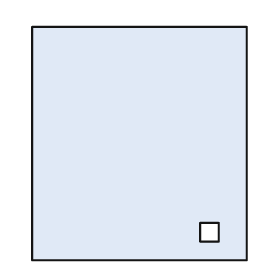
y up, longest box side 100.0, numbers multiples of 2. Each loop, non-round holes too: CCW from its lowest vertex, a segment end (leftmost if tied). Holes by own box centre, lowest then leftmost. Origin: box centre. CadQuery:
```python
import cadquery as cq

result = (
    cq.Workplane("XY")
    .moveTo(-46.0, -50.0)
    .lineTo(46.0, -50.0)
    .lineTo(46.0, 50.0)
    .lineTo(-46.0, 50.0)
    .close()
    .moveTo(26.0, -42.0)
    .lineTo(34.0, -42.0)
    .lineTo(34.0, -34.0)
    .lineTo(26.0, -34.0)
    .close()
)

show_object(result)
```